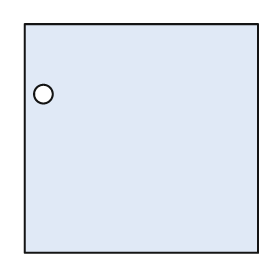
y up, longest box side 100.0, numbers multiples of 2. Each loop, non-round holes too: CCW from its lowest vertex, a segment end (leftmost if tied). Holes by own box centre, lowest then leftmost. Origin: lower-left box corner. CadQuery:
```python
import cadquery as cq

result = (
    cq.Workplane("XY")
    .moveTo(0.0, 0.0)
    .lineTo(100.0, 0.0)
    .lineTo(100.0, 98.0)
    .lineTo(0.0, 98.0)
    .close()
    .moveTo(8.0, 68.0)
    .circle(4.0)
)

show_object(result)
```